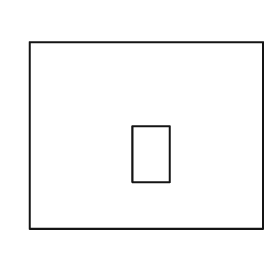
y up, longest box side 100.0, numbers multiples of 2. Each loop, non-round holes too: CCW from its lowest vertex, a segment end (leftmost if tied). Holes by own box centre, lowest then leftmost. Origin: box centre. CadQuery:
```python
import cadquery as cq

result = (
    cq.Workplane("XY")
    .moveTo(-50.0, -40.0)
    .lineTo(50.0, -40.0)
    .lineTo(50.0, 40.0)
    .lineTo(-50.0, 40.0)
    .close()
    .moveTo(-6.0, -20.0)
    .lineTo(10.0, -20.0)
    .lineTo(10.0, 4.0)
    .lineTo(-6.0, 4.0)
    .close()
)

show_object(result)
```